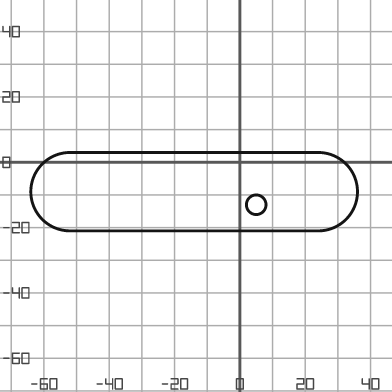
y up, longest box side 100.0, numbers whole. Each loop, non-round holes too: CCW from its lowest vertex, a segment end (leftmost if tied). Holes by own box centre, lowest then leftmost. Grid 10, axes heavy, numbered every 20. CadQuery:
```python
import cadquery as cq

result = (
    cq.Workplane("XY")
    .moveTo(-52.0, -21.0)
    .lineTo(24.0, -21.0)
    .threePointArc((36.0, -9.0), (24.0, 3.0))
    .lineTo(-52.0, 3.0)
    .threePointArc((-64.0, -9.0), (-52.0, -21.0))
    .close()
    .moveTo(5.0, -13.0)
    .circle(3.0)
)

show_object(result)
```